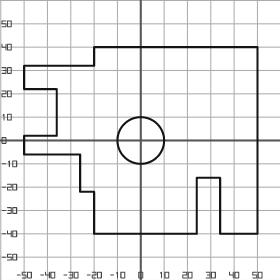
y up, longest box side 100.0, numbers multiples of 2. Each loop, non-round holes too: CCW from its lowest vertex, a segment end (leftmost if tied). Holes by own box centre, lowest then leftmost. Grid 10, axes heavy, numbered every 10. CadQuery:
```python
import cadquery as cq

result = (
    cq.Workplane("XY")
    .moveTo(-20.0, -40.0)
    .lineTo(24.0, -40.0)
    .lineTo(24.0, -16.0)
    .lineTo(34.0, -16.0)
    .lineTo(34.0, -40.0)
    .lineTo(50.0, -40.0)
    .lineTo(50.0, 40.0)
    .lineTo(-20.0, 40.0)
    .lineTo(-20.0, 32.0)
    .lineTo(-50.0, 32.0)
    .lineTo(-50.0, 22.0)
    .lineTo(-36.0, 22.0)
    .lineTo(-36.0, 2.0)
    .lineTo(-50.0, 2.0)
    .lineTo(-50.0, -6.0)
    .lineTo(-26.0, -6.0)
    .lineTo(-26.0, -22.0)
    .lineTo(-20.0, -22.0)
    .close()
    .moveTo(0.0, 0.0)
    .circle(10.0)
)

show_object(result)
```